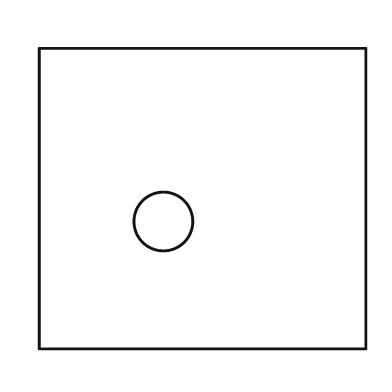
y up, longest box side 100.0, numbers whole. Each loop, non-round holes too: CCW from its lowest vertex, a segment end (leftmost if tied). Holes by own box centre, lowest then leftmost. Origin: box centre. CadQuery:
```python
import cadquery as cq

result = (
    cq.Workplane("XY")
    .moveTo(-50.0, -46.0)
    .lineTo(50.0, -46.0)
    .lineTo(50.0, 46.0)
    .lineTo(-50.0, 46.0)
    .close()
    .moveTo(-12.0, -7.0)
    .circle(9.0)
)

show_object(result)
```